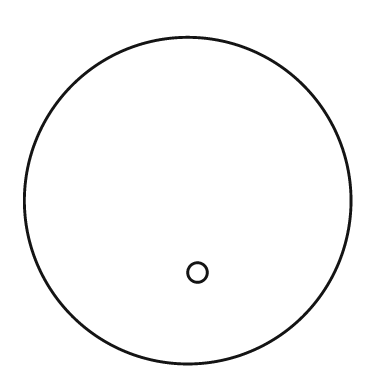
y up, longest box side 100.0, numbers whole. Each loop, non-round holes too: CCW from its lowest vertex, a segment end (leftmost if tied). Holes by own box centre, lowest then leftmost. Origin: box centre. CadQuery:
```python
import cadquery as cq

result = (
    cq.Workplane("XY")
    .moveTo(0.0, 0.0)
    .circle(50.0)
    .moveTo(3.0, -22.0)
    .circle(3.0)
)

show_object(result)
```